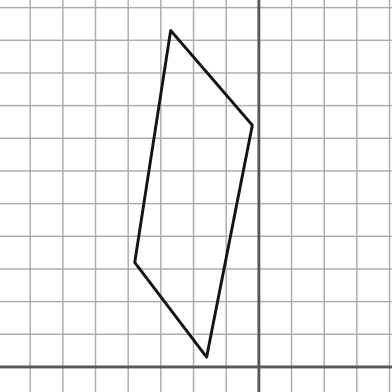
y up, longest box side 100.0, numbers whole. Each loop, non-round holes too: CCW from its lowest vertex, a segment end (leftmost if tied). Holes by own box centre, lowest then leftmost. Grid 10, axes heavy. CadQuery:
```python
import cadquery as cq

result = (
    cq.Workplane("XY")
    .moveTo(-16.0, 3.0)
    .lineTo(-2.0, 74.0)
    .lineTo(-27.0, 103.0)
    .lineTo(-38.0, 32.0)
    .close()
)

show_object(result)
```